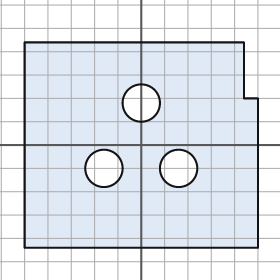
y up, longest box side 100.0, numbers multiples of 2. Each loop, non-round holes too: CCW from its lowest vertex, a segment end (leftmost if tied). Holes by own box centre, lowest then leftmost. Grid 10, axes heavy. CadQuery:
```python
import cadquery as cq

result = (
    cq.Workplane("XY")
    .moveTo(-50.0, -44.0)
    .lineTo(50.0, -44.0)
    .lineTo(50.0, 20.0)
    .lineTo(44.0, 20.0)
    .lineTo(44.0, 44.0)
    .lineTo(-50.0, 44.0)
    .close()
    .moveTo(-16.0, -10.0)
    .circle(8.0)
    .moveTo(16.0, -10.0)
    .circle(8.0)
    .moveTo(0.0, 18.0)
    .circle(8.0)
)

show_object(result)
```